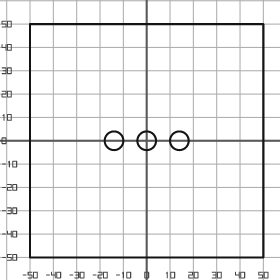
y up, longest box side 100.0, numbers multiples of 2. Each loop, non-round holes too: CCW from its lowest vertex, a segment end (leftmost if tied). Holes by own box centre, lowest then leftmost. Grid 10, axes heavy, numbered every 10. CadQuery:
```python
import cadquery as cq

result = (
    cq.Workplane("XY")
    .moveTo(-50.0, -50.0)
    .lineTo(50.0, -50.0)
    .lineTo(50.0, 50.0)
    .lineTo(-50.0, 50.0)
    .close()
    .moveTo(-14.0, 0.0)
    .circle(4.0)
    .moveTo(0.0, 0.0)
    .circle(4.0)
    .moveTo(14.0, 0.0)
    .circle(4.0)
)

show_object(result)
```